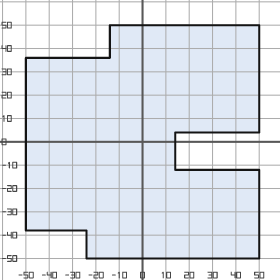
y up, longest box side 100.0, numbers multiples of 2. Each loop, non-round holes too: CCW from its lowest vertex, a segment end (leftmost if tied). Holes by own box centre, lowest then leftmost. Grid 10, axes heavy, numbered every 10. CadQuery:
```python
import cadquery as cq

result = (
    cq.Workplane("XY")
    .moveTo(-24.0, -50.0)
    .lineTo(50.0, -50.0)
    .lineTo(50.0, -12.0)
    .lineTo(14.0, -12.0)
    .lineTo(14.0, 4.0)
    .lineTo(50.0, 4.0)
    .lineTo(50.0, 50.0)
    .lineTo(-14.0, 50.0)
    .lineTo(-14.0, 36.0)
    .lineTo(-50.0, 36.0)
    .lineTo(-50.0, -38.0)
    .lineTo(-24.0, -38.0)
    .close()
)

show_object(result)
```